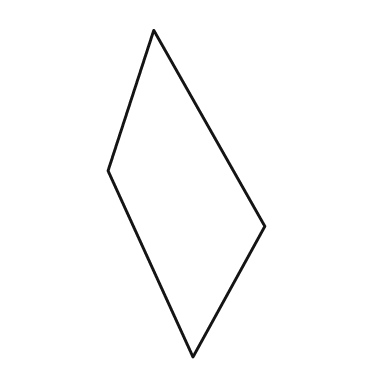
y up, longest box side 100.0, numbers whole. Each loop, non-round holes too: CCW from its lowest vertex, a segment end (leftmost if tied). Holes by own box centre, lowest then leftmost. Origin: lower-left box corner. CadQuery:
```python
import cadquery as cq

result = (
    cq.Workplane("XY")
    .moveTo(26.0, 0.0)
    .lineTo(48.0, 40.0)
    .lineTo(14.0, 100.0)
    .lineTo(0.0, 57.0)
    .close()
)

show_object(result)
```